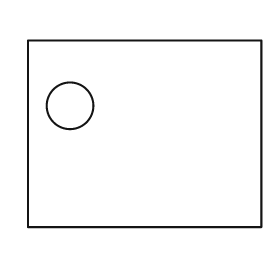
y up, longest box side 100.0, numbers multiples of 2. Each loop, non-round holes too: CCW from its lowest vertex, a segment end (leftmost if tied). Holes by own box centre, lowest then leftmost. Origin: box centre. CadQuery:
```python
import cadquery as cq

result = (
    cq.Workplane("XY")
    .moveTo(-50.0, -40.0)
    .lineTo(50.0, -40.0)
    .lineTo(50.0, 40.0)
    .lineTo(-50.0, 40.0)
    .close()
    .moveTo(-32.0, 12.0)
    .circle(10.0)
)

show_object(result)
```